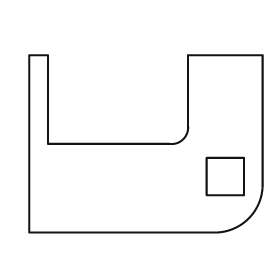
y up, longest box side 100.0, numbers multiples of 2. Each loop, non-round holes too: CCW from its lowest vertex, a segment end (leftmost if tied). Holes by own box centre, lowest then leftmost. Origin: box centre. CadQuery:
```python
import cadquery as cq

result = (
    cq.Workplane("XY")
    .moveTo(-50.0, -38.0)
    .lineTo(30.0, -38.0)
    .threePointArc((44.0, -32.0), (50.0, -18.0))
    .lineTo(50.0, 38.0)
    .lineTo(18.0, 38.0)
    .lineTo(18.0, 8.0)
    .threePointArc((16.0, 2.0), (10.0, 0.0))
    .lineTo(-42.0, 0.0)
    .lineTo(-42.0, 38.0)
    .lineTo(-50.0, 38.0)
    .close()
    .moveTo(26.0, -22.0)
    .lineTo(42.0, -22.0)
    .lineTo(42.0, -6.0)
    .lineTo(26.0, -6.0)
    .close()
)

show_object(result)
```